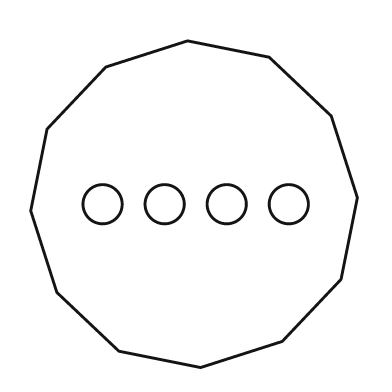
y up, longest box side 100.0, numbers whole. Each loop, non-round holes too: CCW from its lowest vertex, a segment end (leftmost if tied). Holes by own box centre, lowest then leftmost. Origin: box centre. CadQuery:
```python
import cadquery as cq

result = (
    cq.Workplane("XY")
    .moveTo(2.0, -50.0)
    .lineTo(27.0, -42.0)
    .lineTo(45.0, -23.0)
    .lineTo(50.0, 2.0)
    .lineTo(42.0, 27.0)
    .lineTo(23.0, 45.0)
    .lineTo(-2.0, 50.0)
    .lineTo(-27.0, 42.0)
    .lineTo(-45.0, 23.0)
    .lineTo(-50.0, -2.0)
    .lineTo(-42.0, -27.0)
    .lineTo(-23.0, -45.0)
    .close()
    .moveTo(-28.0, 0.0)
    .circle(6.0)
    .moveTo(-9.0, 0.0)
    .circle(6.0)
    .moveTo(10.0, 0.0)
    .circle(6.0)
    .moveTo(29.0, 0.0)
    .circle(6.0)
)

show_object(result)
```